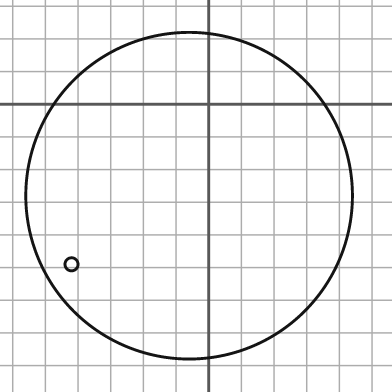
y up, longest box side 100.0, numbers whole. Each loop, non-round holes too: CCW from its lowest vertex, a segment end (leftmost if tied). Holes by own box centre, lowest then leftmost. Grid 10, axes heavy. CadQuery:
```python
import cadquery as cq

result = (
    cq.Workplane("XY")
    .moveTo(-6.0, -28.0)
    .circle(50.0)
    .moveTo(-42.0, -49.0)
    .circle(2.0)
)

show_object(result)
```